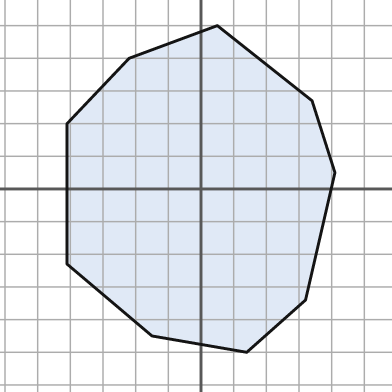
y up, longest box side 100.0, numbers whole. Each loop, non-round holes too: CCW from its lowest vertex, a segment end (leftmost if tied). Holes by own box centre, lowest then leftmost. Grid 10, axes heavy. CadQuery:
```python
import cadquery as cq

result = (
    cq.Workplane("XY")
    .moveTo(14.0, -50.0)
    .lineTo(32.0, -34.0)
    .lineTo(41.0, 5.0)
    .lineTo(34.0, 27.0)
    .lineTo(5.0, 50.0)
    .lineTo(-22.0, 40.0)
    .lineTo(-41.0, 20.0)
    .lineTo(-41.0, -23.0)
    .lineTo(-15.0, -45.0)
    .close()
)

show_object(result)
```